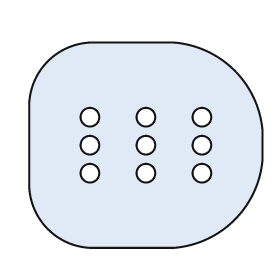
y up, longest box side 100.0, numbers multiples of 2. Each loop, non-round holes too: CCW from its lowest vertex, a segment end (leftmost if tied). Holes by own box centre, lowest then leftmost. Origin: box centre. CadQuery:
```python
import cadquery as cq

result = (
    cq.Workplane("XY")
    .moveTo(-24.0, -44.0)
    .lineTo(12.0, -44.0)
    .threePointArc((38.0, -32.0), (50.0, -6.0))
    .lineTo(50.0, 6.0)
    .threePointArc((38.0, 32.0), (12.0, 44.0))
    .lineTo(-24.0, 44.0)
    .threePointArc((-42.0, 36.0), (-50.0, 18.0))
    .lineTo(-50.0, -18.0)
    .threePointArc((-42.0, -36.0), (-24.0, -44.0))
    .close()
    .moveTo(-24.0, -12.0)
    .circle(4.0)
    .moveTo(0.0, -12.0)
    .circle(4.0)
    .moveTo(24.0, -12.0)
    .circle(4.0)
    .moveTo(-24.0, 0.0)
    .circle(4.0)
    .moveTo(0.0, 0.0)
    .circle(4.0)
    .moveTo(24.0, 0.0)
    .circle(4.0)
    .moveTo(-24.0, 12.0)
    .circle(4.0)
    .moveTo(0.0, 12.0)
    .circle(4.0)
    .moveTo(24.0, 12.0)
    .circle(4.0)
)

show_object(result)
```